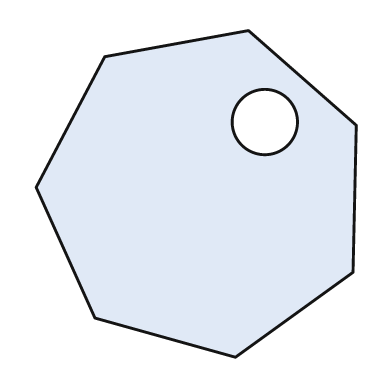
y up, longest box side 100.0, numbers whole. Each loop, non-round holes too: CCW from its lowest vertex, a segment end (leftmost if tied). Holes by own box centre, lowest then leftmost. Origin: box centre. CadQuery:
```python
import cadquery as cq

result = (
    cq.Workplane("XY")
    .moveTo(12.0, -50.0)
    .lineTo(48.0, -24.0)
    .lineTo(49.0, 21.0)
    .lineTo(16.0, 50.0)
    .lineTo(-28.0, 42.0)
    .lineTo(-49.0, 2.0)
    .lineTo(-31.0, -38.0)
    .close()
    .moveTo(21.0, 22.0)
    .circle(10.0)
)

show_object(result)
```